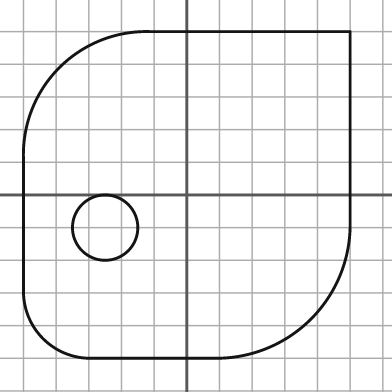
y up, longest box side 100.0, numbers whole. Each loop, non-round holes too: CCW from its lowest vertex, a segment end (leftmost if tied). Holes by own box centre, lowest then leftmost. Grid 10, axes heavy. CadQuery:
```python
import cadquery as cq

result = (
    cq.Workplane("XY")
    .moveTo(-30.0, -50.0)
    .lineTo(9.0, -50.0)
    .threePointArc((38.0, -38.0), (50.0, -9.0))
    .lineTo(50.0, 50.0)
    .lineTo(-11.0, 50.0)
    .threePointArc((-39.0, 39.0), (-50.0, 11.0))
    .lineTo(-50.0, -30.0)
    .threePointArc((-44.0, -44.0), (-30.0, -50.0))
    .close()
    .moveTo(-25.0, -10.0)
    .circle(10.0)
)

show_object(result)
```